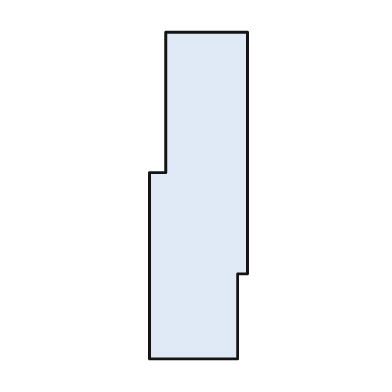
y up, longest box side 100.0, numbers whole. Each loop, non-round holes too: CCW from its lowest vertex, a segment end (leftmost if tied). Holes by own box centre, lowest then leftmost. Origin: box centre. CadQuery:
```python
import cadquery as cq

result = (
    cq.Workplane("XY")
    .moveTo(-15.0, -50.0)
    .lineTo(12.0, -50.0)
    .lineTo(12.0, -24.0)
    .lineTo(15.0, -24.0)
    .lineTo(15.0, 50.0)
    .lineTo(-10.0, 50.0)
    .lineTo(-10.0, 7.0)
    .lineTo(-15.0, 7.0)
    .close()
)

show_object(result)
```